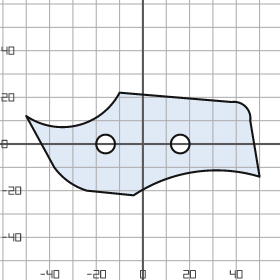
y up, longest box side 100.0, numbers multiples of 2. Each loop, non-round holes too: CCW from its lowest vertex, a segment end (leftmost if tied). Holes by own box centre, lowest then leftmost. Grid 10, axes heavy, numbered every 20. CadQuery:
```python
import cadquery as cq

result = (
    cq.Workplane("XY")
    .moveTo(-4.0, -22.0)
    .threePointArc((22.0, -12.0), (50.0, -14.0))
    .lineTo(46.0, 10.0)
    .threePointArc((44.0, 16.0), (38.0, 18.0))
    .lineTo(-10.0, 22.0)
    .threePointArc((-28.0, 8.0), (-50.0, 12.0))
    .lineTo(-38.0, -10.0)
    .threePointArc((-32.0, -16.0), (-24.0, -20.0))
    .close()
    .moveTo(-16.0, 0.0)
    .circle(4.0)
    .moveTo(16.0, 0.0)
    .circle(4.0)
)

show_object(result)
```